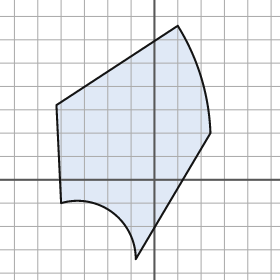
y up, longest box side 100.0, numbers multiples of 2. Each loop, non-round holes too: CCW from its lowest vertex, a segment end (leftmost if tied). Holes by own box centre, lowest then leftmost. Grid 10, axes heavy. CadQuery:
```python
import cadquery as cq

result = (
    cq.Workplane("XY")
    .moveTo(-8.0, -34.0)
    .lineTo(24.0, 20.0)
    .threePointArc((20.0, 44.0), (10.0, 66.0))
    .lineTo(-42.0, 32.0)
    .lineTo(-40.0, -10.0)
    .threePointArc((-18.0, -14.0), (-8.0, -34.0))
    .close()
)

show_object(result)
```